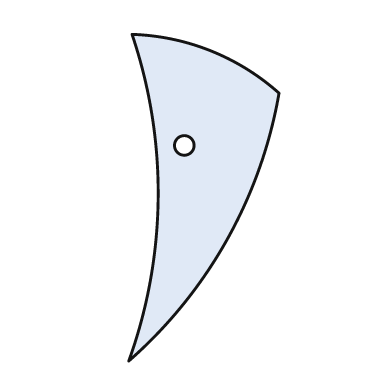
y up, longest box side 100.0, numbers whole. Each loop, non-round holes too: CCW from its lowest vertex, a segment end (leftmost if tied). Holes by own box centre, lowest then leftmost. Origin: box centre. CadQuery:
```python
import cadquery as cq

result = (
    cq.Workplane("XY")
    .moveTo(-23.0, -50.0)
    .threePointArc((7.0, -13.0), (23.0, 32.0))
    .threePointArc((2.0, 45.0), (-22.0, 50.0))
    .threePointArc((-14.0, 0.0), (-23.0, -50.0))
    .close()
    .moveTo(-6.0, 16.0)
    .circle(3.0)
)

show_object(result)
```